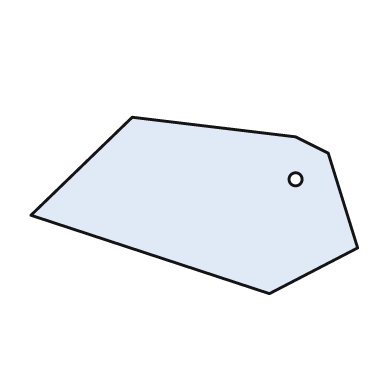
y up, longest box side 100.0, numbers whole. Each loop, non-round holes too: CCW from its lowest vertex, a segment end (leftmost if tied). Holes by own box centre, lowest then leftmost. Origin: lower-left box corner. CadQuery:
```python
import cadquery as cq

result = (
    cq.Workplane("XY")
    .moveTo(73.0, 0.0)
    .lineTo(100.0, 14.0)
    .lineTo(91.0, 43.0)
    .lineTo(81.0, 48.0)
    .lineTo(31.0, 54.0)
    .lineTo(0.0, 24.0)
    .close()
    .moveTo(81.0, 35.0)
    .circle(2.0)
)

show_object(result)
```